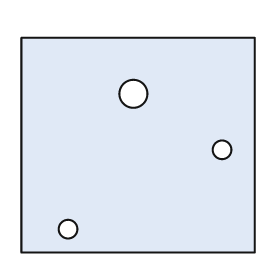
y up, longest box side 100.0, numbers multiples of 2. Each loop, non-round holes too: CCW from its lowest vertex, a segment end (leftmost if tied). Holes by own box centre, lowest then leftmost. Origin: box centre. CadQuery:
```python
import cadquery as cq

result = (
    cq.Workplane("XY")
    .moveTo(-50.0, -46.0)
    .lineTo(50.0, -46.0)
    .lineTo(50.0, 46.0)
    .lineTo(-50.0, 46.0)
    .close()
    .moveTo(-30.0, -36.0)
    .circle(4.0)
    .moveTo(36.0, -2.0)
    .circle(4.0)
    .moveTo(-2.0, 22.0)
    .circle(6.0)
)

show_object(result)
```